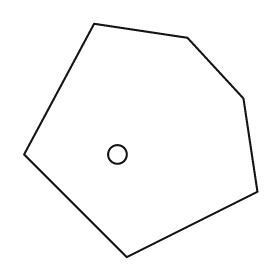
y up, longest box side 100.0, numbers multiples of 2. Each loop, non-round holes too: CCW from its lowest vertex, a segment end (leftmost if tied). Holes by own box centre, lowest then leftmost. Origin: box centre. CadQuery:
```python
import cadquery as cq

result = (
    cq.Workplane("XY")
    .moveTo(-6.0, -50.0)
    .lineTo(50.0, -22.0)
    .lineTo(44.0, 18.0)
    .lineTo(20.0, 44.0)
    .lineTo(-20.0, 50.0)
    .lineTo(-50.0, -6.0)
    .close()
    .moveTo(-10.0, -6.0)
    .circle(4.0)
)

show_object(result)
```